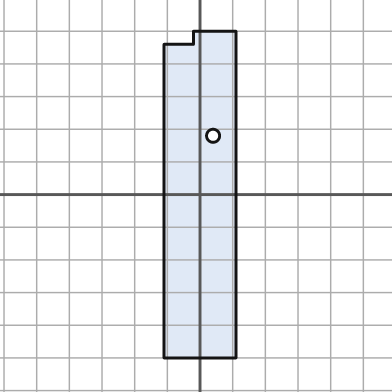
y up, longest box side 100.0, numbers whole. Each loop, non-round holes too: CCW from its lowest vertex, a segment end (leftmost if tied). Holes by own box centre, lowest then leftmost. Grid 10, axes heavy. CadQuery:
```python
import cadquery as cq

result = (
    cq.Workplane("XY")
    .moveTo(-11.0, -50.0)
    .lineTo(11.0, -50.0)
    .lineTo(11.0, 50.0)
    .lineTo(-2.0, 50.0)
    .lineTo(-2.0, 46.0)
    .lineTo(-11.0, 46.0)
    .close()
    .moveTo(4.0, 18.0)
    .circle(2.0)
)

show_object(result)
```